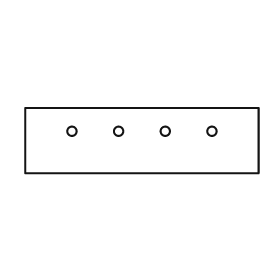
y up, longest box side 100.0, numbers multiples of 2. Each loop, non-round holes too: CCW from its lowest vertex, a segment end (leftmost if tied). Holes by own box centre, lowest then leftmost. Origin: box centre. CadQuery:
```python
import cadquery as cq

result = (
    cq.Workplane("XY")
    .moveTo(-50.0, -14.0)
    .lineTo(50.0, -14.0)
    .lineTo(50.0, 14.0)
    .lineTo(-50.0, 14.0)
    .close()
    .moveTo(-30.0, 4.0)
    .circle(2.0)
    .moveTo(-10.0, 4.0)
    .circle(2.0)
    .moveTo(10.0, 4.0)
    .circle(2.0)
    .moveTo(30.0, 4.0)
    .circle(2.0)
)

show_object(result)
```